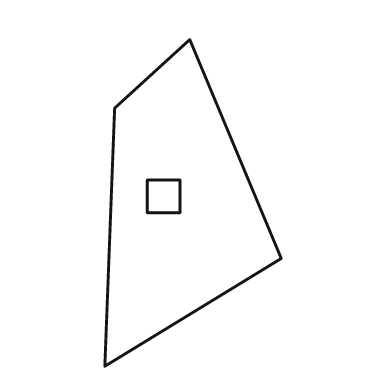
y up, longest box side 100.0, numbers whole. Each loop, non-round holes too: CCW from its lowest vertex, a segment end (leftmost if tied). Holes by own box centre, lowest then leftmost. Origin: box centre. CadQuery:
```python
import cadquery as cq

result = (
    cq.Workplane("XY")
    .moveTo(-27.0, -50.0)
    .lineTo(27.0, -17.0)
    .lineTo(-1.0, 50.0)
    .lineTo(-24.0, 29.0)
    .close()
    .moveTo(-14.0, -3.0)
    .lineTo(-4.0, -3.0)
    .lineTo(-4.0, 7.0)
    .lineTo(-14.0, 7.0)
    .close()
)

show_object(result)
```